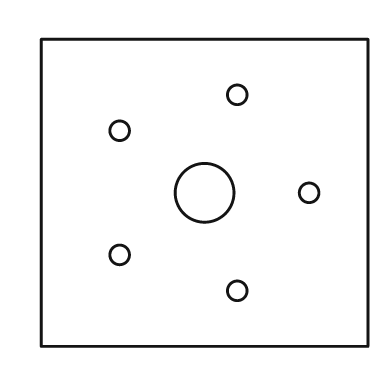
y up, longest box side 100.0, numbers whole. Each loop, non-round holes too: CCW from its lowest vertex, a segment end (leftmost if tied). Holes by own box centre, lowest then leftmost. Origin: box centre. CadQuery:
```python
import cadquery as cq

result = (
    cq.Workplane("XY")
    .moveTo(-50.0, -47.0)
    .lineTo(50.0, -47.0)
    .lineTo(50.0, 47.0)
    .lineTo(-50.0, 47.0)
    .close()
    .moveTo(10.0, -30.0)
    .circle(3.0)
    .moveTo(-26.0, -19.0)
    .circle(3.0)
    .moveTo(0.0, 0.0)
    .circle(9.0)
    .moveTo(32.0, 0.0)
    .circle(3.0)
    .moveTo(-26.0, 19.0)
    .circle(3.0)
    .moveTo(10.0, 30.0)
    .circle(3.0)
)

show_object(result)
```